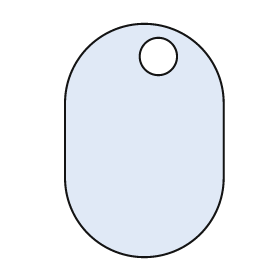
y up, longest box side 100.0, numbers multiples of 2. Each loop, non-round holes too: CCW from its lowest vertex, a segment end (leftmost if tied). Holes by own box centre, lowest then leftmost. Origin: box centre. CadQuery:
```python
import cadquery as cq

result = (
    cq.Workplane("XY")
    .moveTo(-34.0, -16.0)
    .threePointArc((0.0, -50.0), (34.0, -16.0))
    .lineTo(34.0, 16.0)
    .threePointArc((0.0, 50.0), (-34.0, 16.0))
    .close()
    .moveTo(6.0, 36.0)
    .circle(8.0)
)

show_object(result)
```